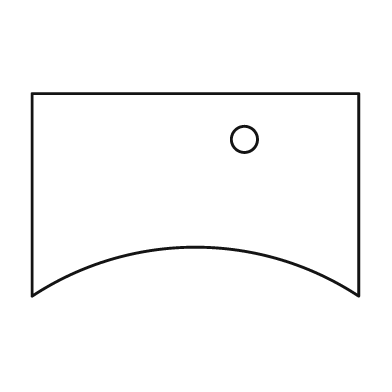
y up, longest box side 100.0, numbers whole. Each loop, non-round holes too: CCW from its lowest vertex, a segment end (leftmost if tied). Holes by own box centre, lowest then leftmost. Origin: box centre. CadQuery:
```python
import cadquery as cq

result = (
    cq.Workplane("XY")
    .moveTo(-50.0, -31.0)
    .threePointArc((0.0, -16.0), (50.0, -31.0))
    .lineTo(50.0, 31.0)
    .lineTo(-50.0, 31.0)
    .close()
    .moveTo(15.0, 17.0)
    .circle(4.0)
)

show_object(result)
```